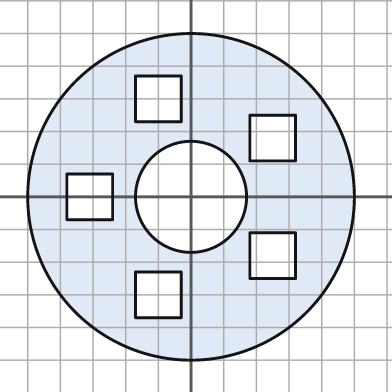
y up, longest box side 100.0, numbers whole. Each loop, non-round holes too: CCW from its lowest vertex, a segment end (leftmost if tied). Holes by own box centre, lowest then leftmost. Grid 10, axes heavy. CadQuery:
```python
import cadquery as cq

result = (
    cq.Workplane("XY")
    .moveTo(0.0, 0.0)
    .circle(50.0)
    .moveTo(-17.0, -37.0)
    .lineTo(-3.0, -37.0)
    .lineTo(-3.0, -23.0)
    .lineTo(-17.0, -23.0)
    .close()
    .moveTo(18.0, -25.0)
    .lineTo(32.0, -25.0)
    .lineTo(32.0, -11.0)
    .lineTo(18.0, -11.0)
    .close()
    .moveTo(-38.0, -7.0)
    .lineTo(-24.0, -7.0)
    .lineTo(-24.0, 7.0)
    .lineTo(-38.0, 7.0)
    .close()
    .moveTo(0.0, 0.0)
    .circle(17.0)
    .moveTo(18.0, 11.0)
    .lineTo(32.0, 11.0)
    .lineTo(32.0, 25.0)
    .lineTo(18.0, 25.0)
    .close()
    .moveTo(-17.0, 23.0)
    .lineTo(-3.0, 23.0)
    .lineTo(-3.0, 37.0)
    .lineTo(-17.0, 37.0)
    .close()
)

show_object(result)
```